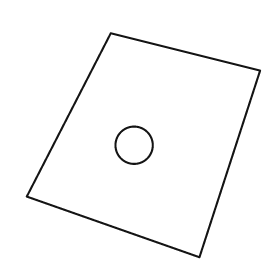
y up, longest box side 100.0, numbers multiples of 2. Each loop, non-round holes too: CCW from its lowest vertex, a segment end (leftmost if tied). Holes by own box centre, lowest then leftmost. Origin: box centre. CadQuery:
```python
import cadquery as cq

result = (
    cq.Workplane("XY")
    .moveTo(24.0, -48.0)
    .lineTo(50.0, 32.0)
    .lineTo(-14.0, 48.0)
    .lineTo(-50.0, -22.0)
    .close()
    .moveTo(-4.0, 0.0)
    .circle(8.0)
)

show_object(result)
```